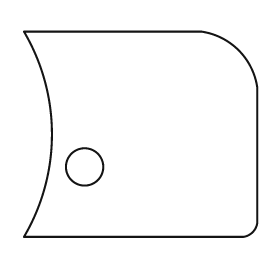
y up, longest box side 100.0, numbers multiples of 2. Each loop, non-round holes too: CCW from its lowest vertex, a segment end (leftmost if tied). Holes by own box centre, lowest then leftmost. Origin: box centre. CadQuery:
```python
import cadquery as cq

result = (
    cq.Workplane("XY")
    .moveTo(-50.0, -44.0)
    .lineTo(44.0, -44.0)
    .threePointArc((48.0, -42.0), (50.0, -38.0))
    .lineTo(50.0, 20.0)
    .threePointArc((42.0, 36.0), (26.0, 44.0))
    .lineTo(-50.0, 44.0)
    .threePointArc((-38.0, 0.0), (-50.0, -44.0))
    .close()
    .moveTo(-24.0, -14.0)
    .circle(8.0)
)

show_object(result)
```